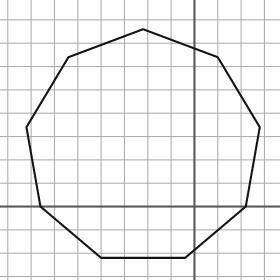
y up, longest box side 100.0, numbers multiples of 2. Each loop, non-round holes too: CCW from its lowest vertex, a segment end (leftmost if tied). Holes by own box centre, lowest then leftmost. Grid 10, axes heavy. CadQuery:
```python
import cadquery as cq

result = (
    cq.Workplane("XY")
    .moveTo(-40.0, -22.0)
    .lineTo(-4.0, -22.0)
    .lineTo(22.0, 0.0)
    .lineTo(28.0, 34.0)
    .lineTo(10.0, 64.0)
    .lineTo(-22.0, 76.0)
    .lineTo(-54.0, 64.0)
    .lineTo(-72.0, 34.0)
    .lineTo(-66.0, 0.0)
    .close()
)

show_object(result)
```